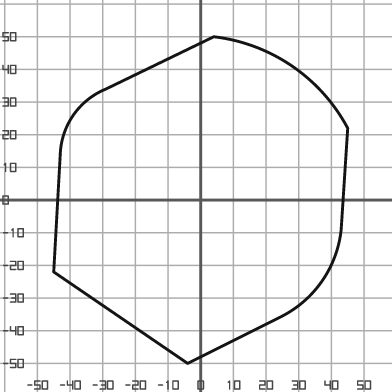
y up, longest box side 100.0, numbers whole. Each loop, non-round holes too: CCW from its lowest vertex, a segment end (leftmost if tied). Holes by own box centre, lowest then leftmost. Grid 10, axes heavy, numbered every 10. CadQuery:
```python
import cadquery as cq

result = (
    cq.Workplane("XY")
    .moveTo(-4.0, -50.0)
    .lineTo(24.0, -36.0)
    .threePointArc((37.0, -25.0), (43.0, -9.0))
    .lineTo(45.0, 22.0)
    .threePointArc((28.0, 41.0), (4.0, 50.0))
    .lineTo(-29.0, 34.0)
    .threePointArc((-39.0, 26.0), (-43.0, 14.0))
    .lineTo(-45.0, -22.0)
    .close()
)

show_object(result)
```